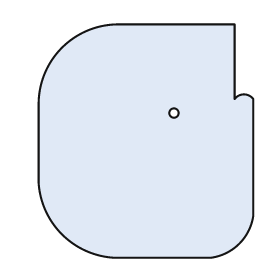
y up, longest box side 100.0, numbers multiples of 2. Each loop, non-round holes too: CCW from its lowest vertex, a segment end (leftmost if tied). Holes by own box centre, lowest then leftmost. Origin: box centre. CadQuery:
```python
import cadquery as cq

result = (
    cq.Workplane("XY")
    .moveTo(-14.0, -50.0)
    .lineTo(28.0, -50.0)
    .threePointArc((40.0, -44.0), (46.0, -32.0))
    .lineTo(46.0, 18.0)
    .threePointArc((42.0, 20.0), (38.0, 18.0))
    .lineTo(38.0, 50.0)
    .lineTo(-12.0, 50.0)
    .threePointArc((-36.0, 40.0), (-46.0, 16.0))
    .lineTo(-46.0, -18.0)
    .threePointArc((-36.0, -40.0), (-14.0, -50.0))
    .close()
    .moveTo(12.0, 12.0)
    .circle(2.0)
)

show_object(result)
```